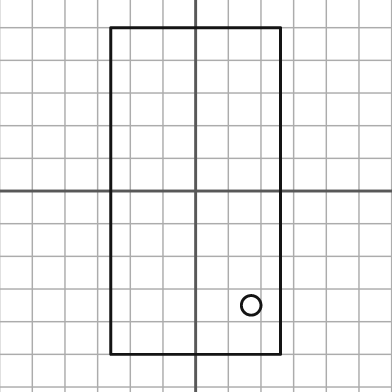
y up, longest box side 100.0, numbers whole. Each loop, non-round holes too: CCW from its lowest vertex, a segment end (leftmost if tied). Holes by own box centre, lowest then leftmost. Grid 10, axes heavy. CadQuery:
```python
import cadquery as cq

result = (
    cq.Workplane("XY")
    .moveTo(-26.0, -50.0)
    .lineTo(26.0, -50.0)
    .lineTo(26.0, 50.0)
    .lineTo(-26.0, 50.0)
    .close()
    .moveTo(17.0, -35.0)
    .circle(3.0)
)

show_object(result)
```